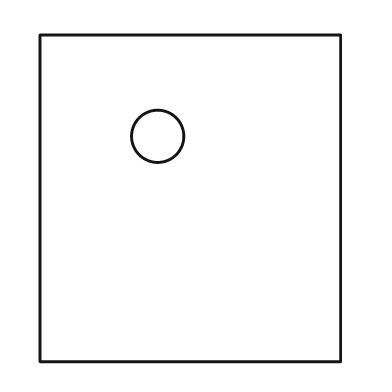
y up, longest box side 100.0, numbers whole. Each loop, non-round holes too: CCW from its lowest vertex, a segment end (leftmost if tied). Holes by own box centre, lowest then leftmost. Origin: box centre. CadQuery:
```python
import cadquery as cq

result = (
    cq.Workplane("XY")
    .moveTo(-46.0, -50.0)
    .lineTo(46.0, -50.0)
    .lineTo(46.0, 50.0)
    .lineTo(-46.0, 50.0)
    .close()
    .moveTo(-10.0, 19.0)
    .circle(8.0)
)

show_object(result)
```